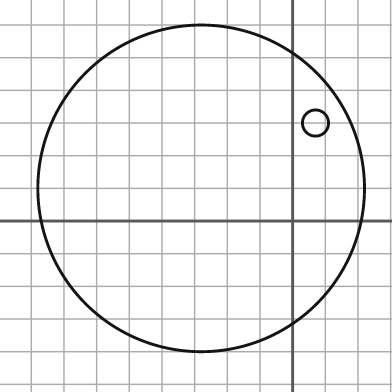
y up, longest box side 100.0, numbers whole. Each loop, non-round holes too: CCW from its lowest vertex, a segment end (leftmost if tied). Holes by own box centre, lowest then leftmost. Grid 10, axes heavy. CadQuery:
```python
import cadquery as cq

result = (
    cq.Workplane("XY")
    .moveTo(-28.0, 10.0)
    .circle(50.0)
    .moveTo(7.0, 30.0)
    .circle(4.0)
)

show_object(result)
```